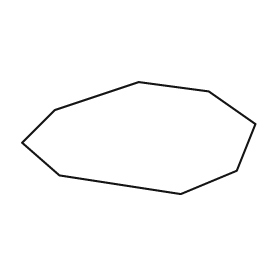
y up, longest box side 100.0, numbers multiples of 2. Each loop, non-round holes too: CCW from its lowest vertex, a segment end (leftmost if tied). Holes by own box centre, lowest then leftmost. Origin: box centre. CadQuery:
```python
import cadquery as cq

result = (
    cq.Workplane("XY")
    .moveTo(18.0, -24.0)
    .lineTo(42.0, -14.0)
    .lineTo(50.0, 6.0)
    .lineTo(30.0, 20.0)
    .lineTo(0.0, 24.0)
    .lineTo(-36.0, 12.0)
    .lineTo(-50.0, -2.0)
    .lineTo(-34.0, -16.0)
    .close()
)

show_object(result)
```